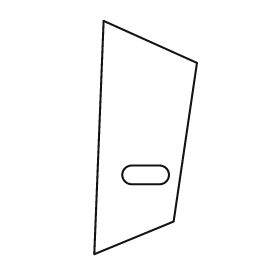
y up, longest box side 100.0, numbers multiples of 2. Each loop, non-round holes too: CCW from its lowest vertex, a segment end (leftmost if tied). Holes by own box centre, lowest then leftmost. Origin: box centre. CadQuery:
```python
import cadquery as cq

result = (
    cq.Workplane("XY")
    .moveTo(-22.0, -50.0)
    .lineTo(12.0, -36.0)
    .lineTo(22.0, 32.0)
    .lineTo(-18.0, 50.0)
    .close()
    .moveTo(-6.0, -20.0)
    .lineTo(6.0, -20.0)
    .threePointArc((10.0, -16.0), (6.0, -12.0))
    .lineTo(-6.0, -12.0)
    .threePointArc((-10.0, -16.0), (-6.0, -20.0))
    .close()
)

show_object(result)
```